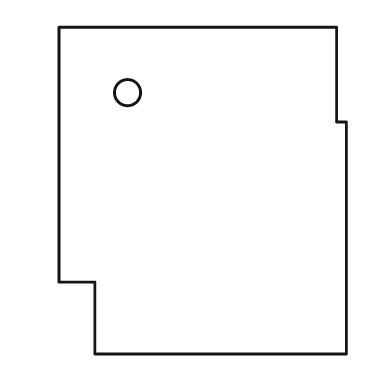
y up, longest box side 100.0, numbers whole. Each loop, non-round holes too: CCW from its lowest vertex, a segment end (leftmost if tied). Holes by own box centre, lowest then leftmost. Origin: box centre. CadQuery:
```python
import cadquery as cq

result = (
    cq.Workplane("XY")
    .moveTo(-33.0, -50.0)
    .lineTo(44.0, -50.0)
    .lineTo(44.0, 21.0)
    .lineTo(41.0, 21.0)
    .lineTo(41.0, 50.0)
    .lineTo(-44.0, 50.0)
    .lineTo(-44.0, -28.0)
    .lineTo(-33.0, -28.0)
    .close()
    .moveTo(-23.0, 30.0)
    .circle(4.0)
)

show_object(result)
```